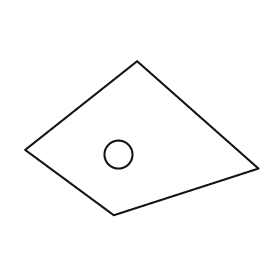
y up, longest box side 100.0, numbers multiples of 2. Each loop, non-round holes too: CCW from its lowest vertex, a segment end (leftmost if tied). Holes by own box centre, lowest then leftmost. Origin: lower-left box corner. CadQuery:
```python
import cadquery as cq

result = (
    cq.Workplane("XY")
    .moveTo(38.0, 0.0)
    .lineTo(100.0, 20.0)
    .lineTo(48.0, 66.0)
    .lineTo(0.0, 28.0)
    .close()
    .moveTo(40.0, 26.0)
    .circle(6.0)
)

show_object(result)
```